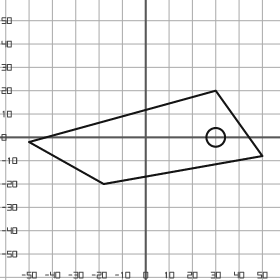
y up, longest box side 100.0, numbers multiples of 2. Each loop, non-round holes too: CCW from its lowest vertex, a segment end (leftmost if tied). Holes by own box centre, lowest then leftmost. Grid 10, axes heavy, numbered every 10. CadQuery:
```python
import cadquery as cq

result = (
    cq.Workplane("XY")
    .moveTo(-18.0, -20.0)
    .lineTo(50.0, -8.0)
    .lineTo(30.0, 20.0)
    .lineTo(-50.0, -2.0)
    .close()
    .moveTo(30.0, 0.0)
    .circle(4.0)
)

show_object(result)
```